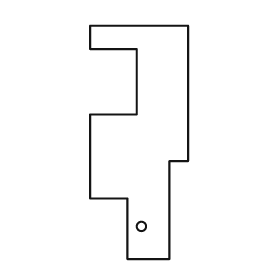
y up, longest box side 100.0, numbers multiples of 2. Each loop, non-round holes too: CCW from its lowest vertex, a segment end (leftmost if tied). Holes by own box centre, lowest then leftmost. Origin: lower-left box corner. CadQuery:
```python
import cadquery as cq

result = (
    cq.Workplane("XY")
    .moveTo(16.0, 0.0)
    .lineTo(34.0, 0.0)
    .lineTo(34.0, 42.0)
    .lineTo(42.0, 42.0)
    .lineTo(42.0, 100.0)
    .lineTo(0.0, 100.0)
    .lineTo(0.0, 90.0)
    .lineTo(20.0, 90.0)
    .lineTo(20.0, 62.0)
    .lineTo(0.0, 62.0)
    .lineTo(0.0, 26.0)
    .lineTo(16.0, 26.0)
    .close()
    .moveTo(22.0, 14.0)
    .circle(2.0)
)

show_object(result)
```